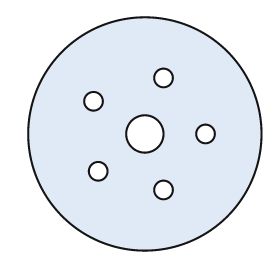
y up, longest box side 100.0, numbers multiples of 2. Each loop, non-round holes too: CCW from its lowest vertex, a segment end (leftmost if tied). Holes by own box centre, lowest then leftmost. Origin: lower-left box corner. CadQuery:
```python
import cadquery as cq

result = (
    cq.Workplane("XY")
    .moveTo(50.0, 50.0)
    .circle(50.0)
    .moveTo(58.0, 26.0)
    .circle(4.0)
    .moveTo(30.0, 34.0)
    .circle(4.0)
    .moveTo(50.0, 50.0)
    .circle(8.0)
    .moveTo(76.0, 50.0)
    .circle(4.0)
    .moveTo(28.0, 64.0)
    .circle(4.0)
    .moveTo(58.0, 74.0)
    .circle(4.0)
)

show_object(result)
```